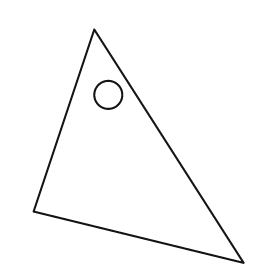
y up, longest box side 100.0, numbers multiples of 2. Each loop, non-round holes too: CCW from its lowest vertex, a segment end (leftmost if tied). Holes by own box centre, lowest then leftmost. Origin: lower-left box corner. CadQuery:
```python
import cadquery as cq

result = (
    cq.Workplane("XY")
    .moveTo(90.0, 0.0)
    .lineTo(26.0, 100.0)
    .lineTo(0.0, 22.0)
    .close()
    .moveTo(32.0, 72.0)
    .circle(6.0)
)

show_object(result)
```